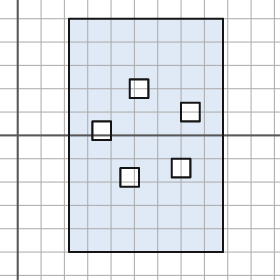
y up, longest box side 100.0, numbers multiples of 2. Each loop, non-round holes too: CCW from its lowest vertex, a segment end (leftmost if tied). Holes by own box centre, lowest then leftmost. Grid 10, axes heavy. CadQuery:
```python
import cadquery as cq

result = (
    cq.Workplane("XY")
    .moveTo(22.0, -50.0)
    .lineTo(88.0, -50.0)
    .lineTo(88.0, 50.0)
    .lineTo(22.0, 50.0)
    .close()
    .moveTo(44.0, -22.0)
    .lineTo(52.0, -22.0)
    .lineTo(52.0, -14.0)
    .lineTo(44.0, -14.0)
    .close()
    .moveTo(66.0, -18.0)
    .lineTo(74.0, -18.0)
    .lineTo(74.0, -10.0)
    .lineTo(66.0, -10.0)
    .close()
    .moveTo(32.0, -2.0)
    .lineTo(40.0, -2.0)
    .lineTo(40.0, 6.0)
    .lineTo(32.0, 6.0)
    .close()
    .moveTo(70.0, 6.0)
    .lineTo(78.0, 6.0)
    .lineTo(78.0, 14.0)
    .lineTo(70.0, 14.0)
    .close()
    .moveTo(48.0, 16.0)
    .lineTo(56.0, 16.0)
    .lineTo(56.0, 24.0)
    .lineTo(48.0, 24.0)
    .close()
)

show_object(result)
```